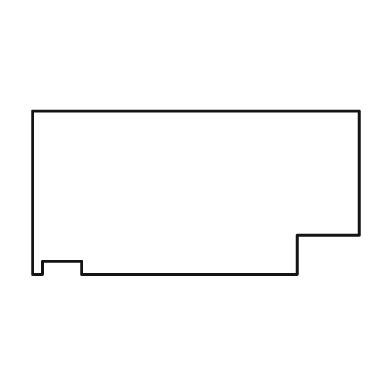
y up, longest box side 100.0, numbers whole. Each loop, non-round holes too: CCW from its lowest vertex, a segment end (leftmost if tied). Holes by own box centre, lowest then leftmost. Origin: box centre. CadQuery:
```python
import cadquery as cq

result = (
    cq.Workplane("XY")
    .moveTo(-50.0, -25.0)
    .lineTo(-47.0, -25.0)
    .lineTo(-47.0, -21.0)
    .lineTo(-35.0, -21.0)
    .lineTo(-35.0, -25.0)
    .lineTo(31.0, -25.0)
    .lineTo(31.0, -13.0)
    .lineTo(50.0, -13.0)
    .lineTo(50.0, 25.0)
    .lineTo(-50.0, 25.0)
    .close()
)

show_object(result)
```